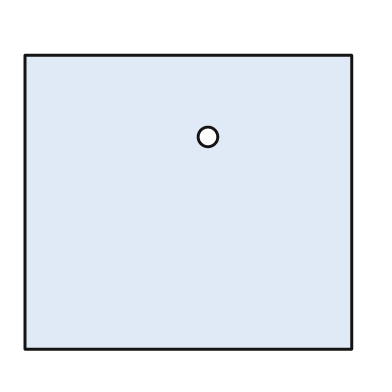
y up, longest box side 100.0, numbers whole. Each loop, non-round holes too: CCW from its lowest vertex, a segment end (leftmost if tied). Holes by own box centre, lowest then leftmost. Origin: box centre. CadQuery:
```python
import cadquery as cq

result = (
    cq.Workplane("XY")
    .moveTo(-50.0, -45.0)
    .lineTo(50.0, -45.0)
    .lineTo(50.0, 45.0)
    .lineTo(-50.0, 45.0)
    .close()
    .moveTo(6.0, 20.0)
    .circle(3.0)
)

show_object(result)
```